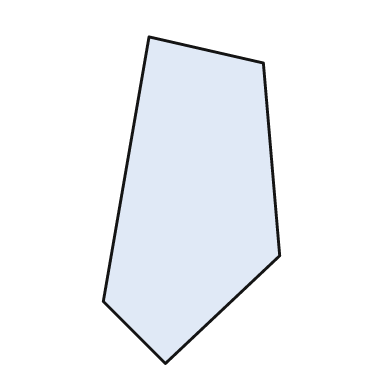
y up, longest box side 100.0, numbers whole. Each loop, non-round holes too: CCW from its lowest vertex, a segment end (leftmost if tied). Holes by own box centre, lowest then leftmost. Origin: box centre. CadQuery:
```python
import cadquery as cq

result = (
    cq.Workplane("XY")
    .moveTo(-8.0, -50.0)
    .lineTo(27.0, -17.0)
    .lineTo(22.0, 42.0)
    .lineTo(-13.0, 50.0)
    .lineTo(-27.0, -31.0)
    .close()
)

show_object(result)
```